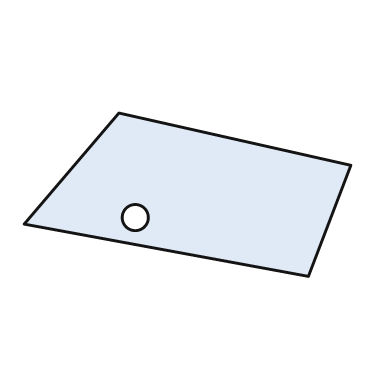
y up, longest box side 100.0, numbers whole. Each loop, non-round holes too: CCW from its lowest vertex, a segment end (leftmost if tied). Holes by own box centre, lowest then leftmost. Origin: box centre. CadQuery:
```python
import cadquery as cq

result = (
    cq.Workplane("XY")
    .moveTo(37.0, -25.0)
    .lineTo(50.0, 9.0)
    .lineTo(-21.0, 25.0)
    .lineTo(-50.0, -9.0)
    .close()
    .moveTo(-16.0, -7.0)
    .circle(4.0)
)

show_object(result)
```